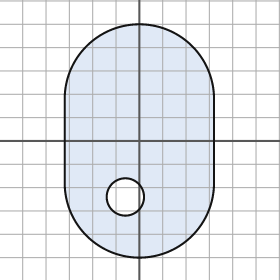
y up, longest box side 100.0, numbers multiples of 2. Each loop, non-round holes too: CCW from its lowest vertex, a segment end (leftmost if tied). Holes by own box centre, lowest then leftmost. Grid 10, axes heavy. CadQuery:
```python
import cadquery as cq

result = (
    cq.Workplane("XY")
    .moveTo(-32.0, -18.0)
    .threePointArc((0.0, -50.0), (32.0, -18.0))
    .lineTo(32.0, 18.0)
    .threePointArc((0.0, 50.0), (-32.0, 18.0))
    .close()
    .moveTo(-6.0, -24.0)
    .circle(8.0)
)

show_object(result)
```